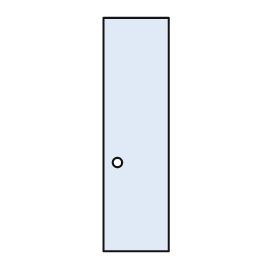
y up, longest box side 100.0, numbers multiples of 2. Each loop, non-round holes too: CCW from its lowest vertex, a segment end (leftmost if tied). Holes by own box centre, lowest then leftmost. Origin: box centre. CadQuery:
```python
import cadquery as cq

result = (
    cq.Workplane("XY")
    .moveTo(-14.0, -50.0)
    .lineTo(14.0, -50.0)
    .lineTo(14.0, 50.0)
    .lineTo(-14.0, 50.0)
    .close()
    .moveTo(-8.0, -12.0)
    .circle(2.0)
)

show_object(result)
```